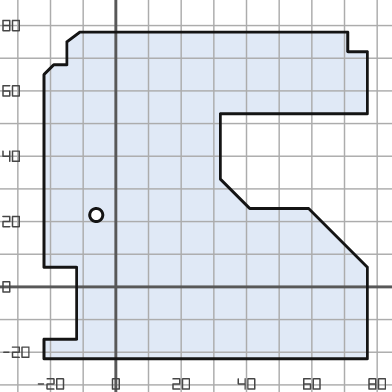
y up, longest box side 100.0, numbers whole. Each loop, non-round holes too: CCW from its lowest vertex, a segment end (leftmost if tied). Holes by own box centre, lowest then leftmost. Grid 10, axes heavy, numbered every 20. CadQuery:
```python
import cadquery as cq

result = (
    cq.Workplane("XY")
    .moveTo(-22.0, -22.0)
    .lineTo(77.0, -22.0)
    .lineTo(77.0, 6.0)
    .lineTo(59.0, 24.0)
    .lineTo(41.0, 24.0)
    .lineTo(32.0, 33.0)
    .lineTo(32.0, 53.0)
    .lineTo(77.0, 53.0)
    .lineTo(77.0, 72.0)
    .lineTo(71.0, 72.0)
    .lineTo(71.0, 78.0)
    .lineTo(-11.0, 78.0)
    .lineTo(-15.0, 75.0)
    .lineTo(-15.0, 68.0)
    .lineTo(-19.0, 68.0)
    .lineTo(-22.0, 65.0)
    .lineTo(-22.0, 6.0)
    .lineTo(-12.0, 6.0)
    .lineTo(-12.0, -16.0)
    .lineTo(-22.0, -16.0)
    .close()
    .moveTo(-6.0, 22.0)
    .circle(2.0)
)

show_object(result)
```